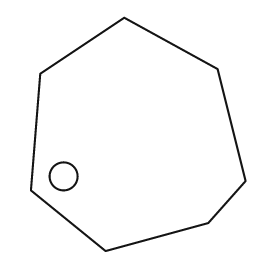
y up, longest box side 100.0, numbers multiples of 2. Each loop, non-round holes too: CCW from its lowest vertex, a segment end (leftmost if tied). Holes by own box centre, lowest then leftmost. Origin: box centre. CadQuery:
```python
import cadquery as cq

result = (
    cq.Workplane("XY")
    .moveTo(-14.0, -50.0)
    .lineTo(30.0, -38.0)
    .lineTo(46.0, -20.0)
    .lineTo(34.0, 28.0)
    .lineTo(-6.0, 50.0)
    .lineTo(-42.0, 26.0)
    .lineTo(-46.0, -24.0)
    .close()
    .moveTo(-32.0, -18.0)
    .circle(6.0)
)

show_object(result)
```